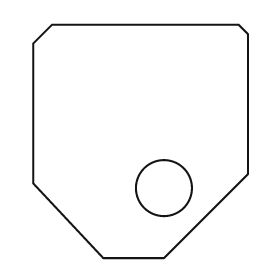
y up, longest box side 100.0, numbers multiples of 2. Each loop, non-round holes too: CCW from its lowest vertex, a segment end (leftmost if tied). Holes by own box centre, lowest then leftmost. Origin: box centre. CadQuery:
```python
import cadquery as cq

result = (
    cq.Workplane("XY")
    .moveTo(-16.0, -50.0)
    .lineTo(10.0, -50.0)
    .lineTo(46.0, -14.0)
    .lineTo(46.0, 46.0)
    .lineTo(42.0, 50.0)
    .lineTo(-38.0, 50.0)
    .lineTo(-46.0, 42.0)
    .lineTo(-46.0, -18.0)
    .close()
    .moveTo(10.0, -20.0)
    .circle(12.0)
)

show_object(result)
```